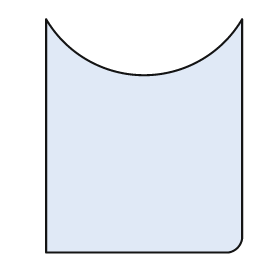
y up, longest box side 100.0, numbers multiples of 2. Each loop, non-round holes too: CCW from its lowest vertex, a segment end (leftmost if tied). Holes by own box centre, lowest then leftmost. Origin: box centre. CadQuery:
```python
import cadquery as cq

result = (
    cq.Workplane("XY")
    .moveTo(-42.0, -50.0)
    .lineTo(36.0, -50.0)
    .threePointArc((40.0, -48.0), (42.0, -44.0))
    .lineTo(42.0, 50.0)
    .threePointArc((0.0, 26.0), (-42.0, 50.0))
    .close()
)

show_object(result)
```